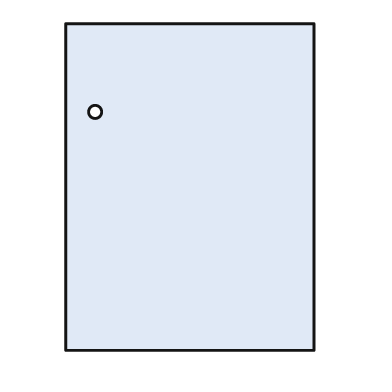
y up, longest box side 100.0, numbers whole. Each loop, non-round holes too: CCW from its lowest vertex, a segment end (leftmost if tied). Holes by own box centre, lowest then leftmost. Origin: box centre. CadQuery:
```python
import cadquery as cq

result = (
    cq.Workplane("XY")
    .moveTo(-38.0, -50.0)
    .lineTo(38.0, -50.0)
    .lineTo(38.0, 50.0)
    .lineTo(-38.0, 50.0)
    .close()
    .moveTo(-29.0, 23.0)
    .circle(2.0)
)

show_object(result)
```